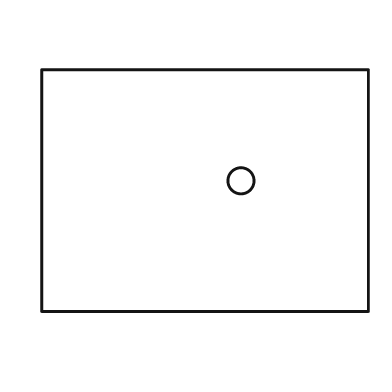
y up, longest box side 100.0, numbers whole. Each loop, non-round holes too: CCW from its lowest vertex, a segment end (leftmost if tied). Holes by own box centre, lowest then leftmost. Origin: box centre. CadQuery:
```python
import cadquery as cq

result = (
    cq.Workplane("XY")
    .moveTo(-50.0, -37.0)
    .lineTo(50.0, -37.0)
    .lineTo(50.0, 37.0)
    .lineTo(-50.0, 37.0)
    .close()
    .moveTo(11.0, 3.0)
    .circle(4.0)
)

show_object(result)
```